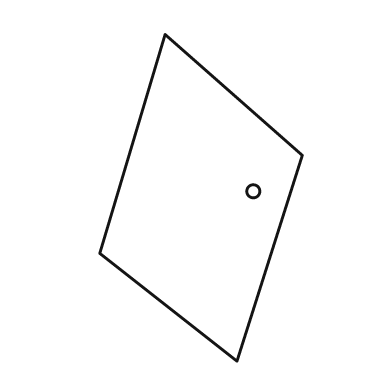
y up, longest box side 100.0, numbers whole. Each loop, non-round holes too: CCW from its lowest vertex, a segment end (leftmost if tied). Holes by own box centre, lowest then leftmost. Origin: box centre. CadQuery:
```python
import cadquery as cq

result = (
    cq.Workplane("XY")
    .moveTo(11.0, -50.0)
    .lineTo(31.0, 13.0)
    .lineTo(-11.0, 50.0)
    .lineTo(-31.0, -17.0)
    .close()
    .moveTo(16.0, 2.0)
    .circle(2.0)
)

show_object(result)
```